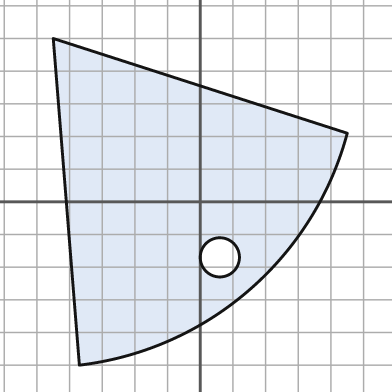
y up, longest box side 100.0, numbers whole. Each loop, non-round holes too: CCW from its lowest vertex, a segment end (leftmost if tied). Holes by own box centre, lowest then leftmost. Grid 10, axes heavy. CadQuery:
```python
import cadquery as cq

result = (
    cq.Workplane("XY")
    .moveTo(-37.0, -50.0)
    .threePointArc((15.0, -27.0), (45.0, 21.0))
    .lineTo(-45.0, 50.0)
    .close()
    .moveTo(6.0, -17.0)
    .circle(6.0)
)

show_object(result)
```